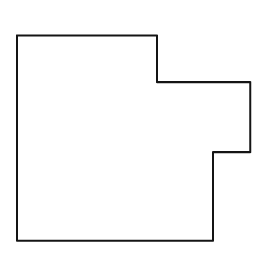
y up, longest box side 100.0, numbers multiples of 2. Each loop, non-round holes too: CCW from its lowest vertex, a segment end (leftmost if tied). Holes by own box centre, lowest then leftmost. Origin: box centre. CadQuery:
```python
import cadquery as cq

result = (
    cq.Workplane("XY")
    .moveTo(-50.0, -44.0)
    .lineTo(34.0, -44.0)
    .lineTo(34.0, -6.0)
    .lineTo(50.0, -6.0)
    .lineTo(50.0, 24.0)
    .lineTo(10.0, 24.0)
    .lineTo(10.0, 44.0)
    .lineTo(-50.0, 44.0)
    .close()
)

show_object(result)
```